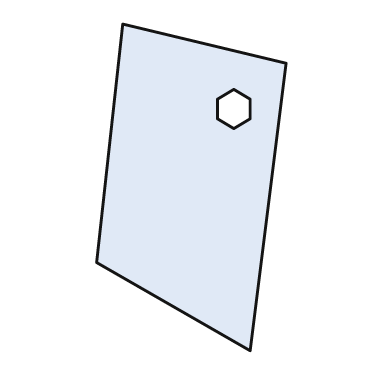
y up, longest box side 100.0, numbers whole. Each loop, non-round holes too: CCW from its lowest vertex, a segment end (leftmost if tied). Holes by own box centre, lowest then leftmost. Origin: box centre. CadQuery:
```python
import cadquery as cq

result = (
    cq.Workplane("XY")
    .moveTo(18.0, -50.0)
    .lineTo(29.0, 38.0)
    .lineTo(-21.0, 50.0)
    .lineTo(-29.0, -23.0)
    .close()
    .moveTo(13.0, 18.0)
    .lineTo(18.0, 21.0)
    .lineTo(18.0, 27.0)
    .lineTo(13.0, 30.0)
    .lineTo(8.0, 27.0)
    .lineTo(8.0, 21.0)
    .close()
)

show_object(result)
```